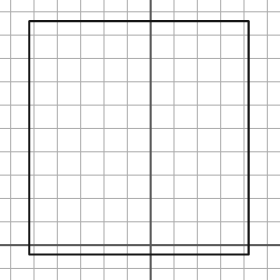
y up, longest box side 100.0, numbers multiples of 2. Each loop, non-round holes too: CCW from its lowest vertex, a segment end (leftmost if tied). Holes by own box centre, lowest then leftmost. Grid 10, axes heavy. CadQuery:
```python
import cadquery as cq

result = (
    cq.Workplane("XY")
    .moveTo(-52.0, -4.0)
    .lineTo(42.0, -4.0)
    .lineTo(42.0, 96.0)
    .lineTo(-52.0, 96.0)
    .close()
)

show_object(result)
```